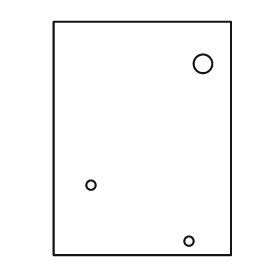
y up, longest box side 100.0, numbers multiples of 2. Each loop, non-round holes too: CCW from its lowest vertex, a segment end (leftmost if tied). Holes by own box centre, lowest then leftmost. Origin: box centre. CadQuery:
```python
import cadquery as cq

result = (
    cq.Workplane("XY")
    .moveTo(-38.0, -50.0)
    .lineTo(38.0, -50.0)
    .lineTo(38.0, 50.0)
    .lineTo(-38.0, 50.0)
    .close()
    .moveTo(20.0, -44.0)
    .circle(2.0)
    .moveTo(-22.0, -20.0)
    .circle(2.0)
    .moveTo(26.0, 32.0)
    .circle(4.0)
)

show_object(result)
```